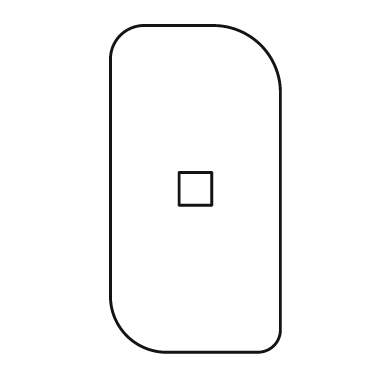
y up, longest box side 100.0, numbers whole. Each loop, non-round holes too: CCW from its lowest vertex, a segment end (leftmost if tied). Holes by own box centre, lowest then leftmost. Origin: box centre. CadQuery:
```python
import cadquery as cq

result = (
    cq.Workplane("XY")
    .moveTo(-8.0, -50.0)
    .lineTo(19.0, -50.0)
    .threePointArc((24.0, -48.0), (26.0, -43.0))
    .lineTo(26.0, 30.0)
    .threePointArc((20.0, 44.0), (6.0, 50.0))
    .lineTo(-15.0, 50.0)
    .threePointArc((-23.0, 47.0), (-26.0, 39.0))
    .lineTo(-26.0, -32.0)
    .threePointArc((-21.0, -45.0), (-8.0, -50.0))
    .close()
    .moveTo(-5.0, -5.0)
    .lineTo(5.0, -5.0)
    .lineTo(5.0, 5.0)
    .lineTo(-5.0, 5.0)
    .close()
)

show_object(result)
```